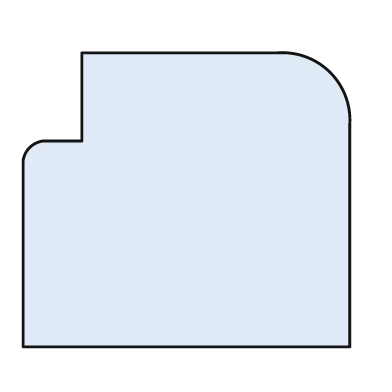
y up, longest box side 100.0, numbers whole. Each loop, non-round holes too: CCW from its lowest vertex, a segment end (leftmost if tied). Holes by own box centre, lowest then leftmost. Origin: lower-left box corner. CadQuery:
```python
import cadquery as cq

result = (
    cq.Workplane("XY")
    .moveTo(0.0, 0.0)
    .lineTo(100.0, 0.0)
    .lineTo(100.0, 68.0)
    .threePointArc((94.0, 84.0), (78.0, 90.0))
    .lineTo(18.0, 90.0)
    .lineTo(18.0, 63.0)
    .lineTo(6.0, 63.0)
    .threePointArc((2.0, 61.0), (0.0, 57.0))
    .close()
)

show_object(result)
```